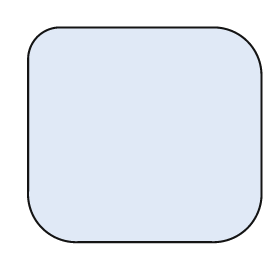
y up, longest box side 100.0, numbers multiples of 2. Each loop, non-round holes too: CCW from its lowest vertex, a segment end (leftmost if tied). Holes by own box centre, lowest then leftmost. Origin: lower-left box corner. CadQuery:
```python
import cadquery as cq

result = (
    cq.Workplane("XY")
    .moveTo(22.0, 0.0)
    .lineTo(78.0, 0.0)
    .threePointArc((94.0, 6.0), (100.0, 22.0))
    .lineTo(100.0, 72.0)
    .threePointArc((94.0, 86.0), (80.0, 92.0))
    .lineTo(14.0, 92.0)
    .threePointArc((4.0, 88.0), (0.0, 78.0))
    .lineTo(0.0, 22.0)
    .threePointArc((6.0, 6.0), (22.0, 0.0))
    .close()
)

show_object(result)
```